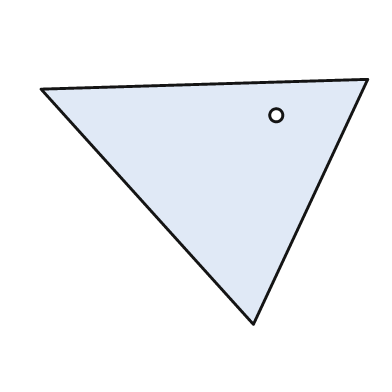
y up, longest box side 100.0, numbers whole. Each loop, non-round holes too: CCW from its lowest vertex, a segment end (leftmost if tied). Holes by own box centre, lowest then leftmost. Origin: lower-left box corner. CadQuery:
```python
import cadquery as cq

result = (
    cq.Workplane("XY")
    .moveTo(65.0, 0.0)
    .lineTo(100.0, 75.0)
    .lineTo(0.0, 72.0)
    .close()
    .moveTo(72.0, 64.0)
    .circle(2.0)
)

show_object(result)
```